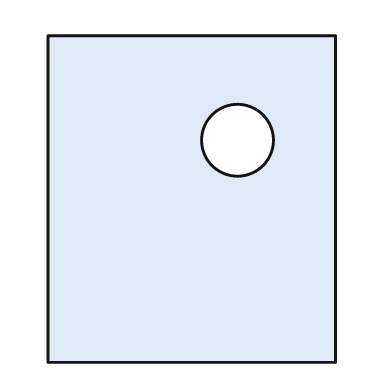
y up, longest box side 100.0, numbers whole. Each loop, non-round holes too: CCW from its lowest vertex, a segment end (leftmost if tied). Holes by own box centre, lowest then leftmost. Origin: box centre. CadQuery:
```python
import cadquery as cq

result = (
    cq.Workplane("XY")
    .moveTo(-44.0, -50.0)
    .lineTo(44.0, -50.0)
    .lineTo(44.0, 50.0)
    .lineTo(-44.0, 50.0)
    .close()
    .moveTo(14.0, 18.0)
    .circle(11.0)
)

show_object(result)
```